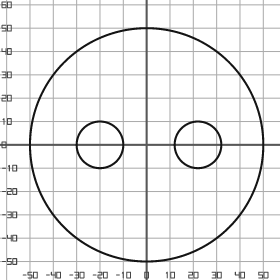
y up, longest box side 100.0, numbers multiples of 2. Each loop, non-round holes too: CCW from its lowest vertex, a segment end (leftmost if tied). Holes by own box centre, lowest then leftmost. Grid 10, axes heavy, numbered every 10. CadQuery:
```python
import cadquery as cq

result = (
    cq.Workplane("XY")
    .moveTo(0.0, 0.0)
    .circle(50.0)
    .moveTo(-20.0, 0.0)
    .circle(10.0)
    .moveTo(22.0, 0.0)
    .circle(10.0)
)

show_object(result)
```